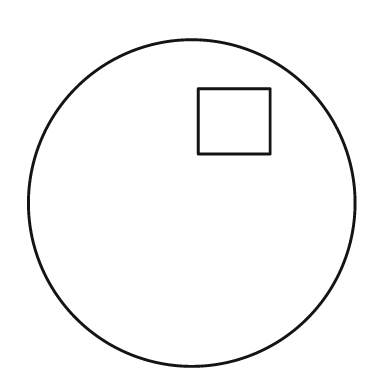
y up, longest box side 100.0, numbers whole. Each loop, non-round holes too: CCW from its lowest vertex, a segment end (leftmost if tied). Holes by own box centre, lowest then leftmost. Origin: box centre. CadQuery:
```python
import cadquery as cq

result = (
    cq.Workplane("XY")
    .moveTo(0.0, 0.0)
    .circle(50.0)
    .moveTo(2.0, 15.0)
    .lineTo(24.0, 15.0)
    .lineTo(24.0, 35.0)
    .lineTo(2.0, 35.0)
    .close()
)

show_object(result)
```